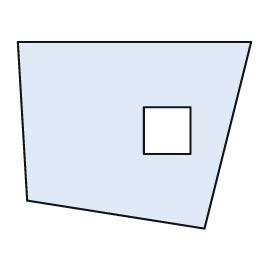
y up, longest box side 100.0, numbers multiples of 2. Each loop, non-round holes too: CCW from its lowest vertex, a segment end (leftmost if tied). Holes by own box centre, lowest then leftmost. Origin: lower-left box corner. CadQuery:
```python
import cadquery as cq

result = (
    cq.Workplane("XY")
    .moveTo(80.0, 0.0)
    .lineTo(100.0, 80.0)
    .lineTo(0.0, 80.0)
    .lineTo(4.0, 12.0)
    .close()
    .moveTo(54.0, 32.0)
    .lineTo(74.0, 32.0)
    .lineTo(74.0, 52.0)
    .lineTo(54.0, 52.0)
    .close()
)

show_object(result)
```